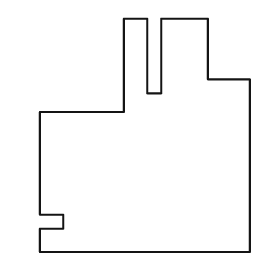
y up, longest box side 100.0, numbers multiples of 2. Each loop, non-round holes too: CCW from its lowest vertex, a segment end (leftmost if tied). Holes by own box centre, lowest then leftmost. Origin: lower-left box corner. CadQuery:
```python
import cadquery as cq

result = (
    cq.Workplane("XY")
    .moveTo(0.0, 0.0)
    .lineTo(90.0, 0.0)
    .lineTo(90.0, 74.0)
    .lineTo(72.0, 74.0)
    .lineTo(72.0, 100.0)
    .lineTo(52.0, 100.0)
    .lineTo(52.0, 68.0)
    .lineTo(46.0, 68.0)
    .lineTo(46.0, 100.0)
    .lineTo(36.0, 100.0)
    .lineTo(36.0, 60.0)
    .lineTo(0.0, 60.0)
    .lineTo(0.0, 16.0)
    .lineTo(10.0, 16.0)
    .lineTo(10.0, 10.0)
    .lineTo(0.0, 10.0)
    .close()
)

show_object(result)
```